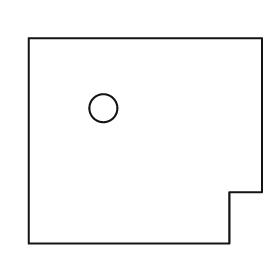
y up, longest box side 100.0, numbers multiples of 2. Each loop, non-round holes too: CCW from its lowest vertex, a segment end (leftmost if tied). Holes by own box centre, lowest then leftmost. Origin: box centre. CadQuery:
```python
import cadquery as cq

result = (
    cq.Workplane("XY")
    .moveTo(-50.0, -44.0)
    .lineTo(36.0, -44.0)
    .lineTo(36.0, -22.0)
    .lineTo(50.0, -22.0)
    .lineTo(50.0, 44.0)
    .lineTo(-50.0, 44.0)
    .close()
    .moveTo(-18.0, 14.0)
    .circle(6.0)
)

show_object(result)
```